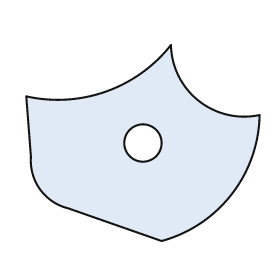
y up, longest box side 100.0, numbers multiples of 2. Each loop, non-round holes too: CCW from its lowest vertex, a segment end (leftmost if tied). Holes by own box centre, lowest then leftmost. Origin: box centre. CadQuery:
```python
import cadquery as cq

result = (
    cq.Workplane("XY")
    .moveTo(8.0, -42.0)
    .threePointArc((38.0, -22.0), (50.0, 12.0))
    .threePointArc((24.0, 18.0), (12.0, 42.0))
    .threePointArc((-16.0, 22.0), (-50.0, 20.0))
    .lineTo(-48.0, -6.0)
    .threePointArc((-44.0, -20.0), (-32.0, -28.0))
    .close()
    .moveTo(0.0, 0.0)
    .circle(8.0)
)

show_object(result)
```